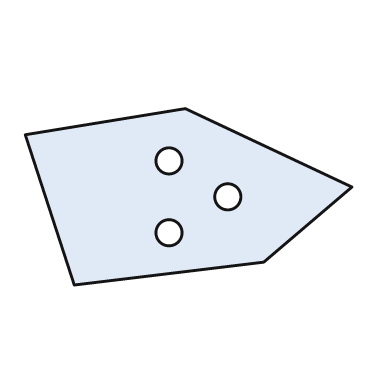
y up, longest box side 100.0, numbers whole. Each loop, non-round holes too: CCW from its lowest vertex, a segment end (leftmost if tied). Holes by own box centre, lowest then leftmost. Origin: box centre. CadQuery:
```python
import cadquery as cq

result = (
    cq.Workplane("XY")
    .moveTo(-35.0, -27.0)
    .lineTo(23.0, -20.0)
    .lineTo(50.0, 3.0)
    .lineTo(-1.0, 27.0)
    .lineTo(-50.0, 19.0)
    .close()
    .moveTo(-6.0, -11.0)
    .circle(4.0)
    .moveTo(12.0, 0.0)
    .circle(4.0)
    .moveTo(-6.0, 11.0)
    .circle(4.0)
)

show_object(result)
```